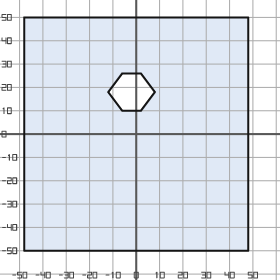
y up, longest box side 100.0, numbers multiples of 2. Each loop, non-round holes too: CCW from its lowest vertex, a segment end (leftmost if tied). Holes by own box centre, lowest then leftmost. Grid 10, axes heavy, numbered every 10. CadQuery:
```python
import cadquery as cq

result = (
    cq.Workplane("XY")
    .moveTo(-48.0, -50.0)
    .lineTo(48.0, -50.0)
    .lineTo(48.0, 50.0)
    .lineTo(-48.0, 50.0)
    .close()
    .moveTo(-6.0, 10.0)
    .lineTo(2.0, 10.0)
    .lineTo(8.0, 18.0)
    .lineTo(2.0, 26.0)
    .lineTo(-6.0, 26.0)
    .lineTo(-12.0, 18.0)
    .close()
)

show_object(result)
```